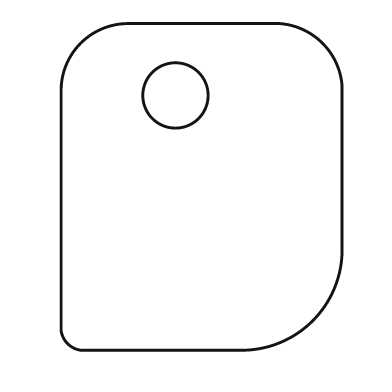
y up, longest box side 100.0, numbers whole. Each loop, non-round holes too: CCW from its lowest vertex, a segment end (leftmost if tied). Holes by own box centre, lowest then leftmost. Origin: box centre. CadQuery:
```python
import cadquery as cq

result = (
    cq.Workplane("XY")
    .moveTo(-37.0, -50.0)
    .lineTo(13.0, -50.0)
    .threePointArc((34.0, -41.0), (43.0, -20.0))
    .lineTo(43.0, 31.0)
    .threePointArc((37.0, 44.0), (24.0, 50.0))
    .lineTo(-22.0, 50.0)
    .threePointArc((-37.0, 44.0), (-43.0, 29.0))
    .lineTo(-43.0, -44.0)
    .threePointArc((-41.0, -48.0), (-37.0, -50.0))
    .close()
    .moveTo(-8.0, 28.0)
    .circle(10.0)
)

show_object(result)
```